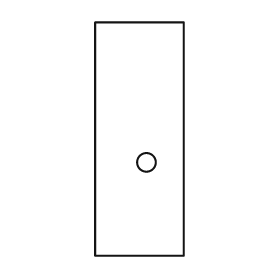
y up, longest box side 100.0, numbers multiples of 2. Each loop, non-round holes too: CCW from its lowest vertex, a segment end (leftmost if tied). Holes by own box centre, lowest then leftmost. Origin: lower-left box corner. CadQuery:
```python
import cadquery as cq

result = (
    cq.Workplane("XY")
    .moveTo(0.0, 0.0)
    .lineTo(38.0, 0.0)
    .lineTo(38.0, 100.0)
    .lineTo(0.0, 100.0)
    .close()
    .moveTo(22.0, 40.0)
    .circle(4.0)
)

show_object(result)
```